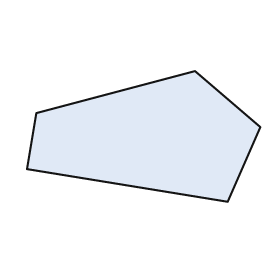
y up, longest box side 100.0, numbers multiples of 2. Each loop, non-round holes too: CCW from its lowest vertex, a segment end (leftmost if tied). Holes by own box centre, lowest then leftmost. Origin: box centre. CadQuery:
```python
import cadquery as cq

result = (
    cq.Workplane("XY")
    .moveTo(36.0, -28.0)
    .lineTo(50.0, 4.0)
    .lineTo(22.0, 28.0)
    .lineTo(-46.0, 10.0)
    .lineTo(-50.0, -14.0)
    .close()
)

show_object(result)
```